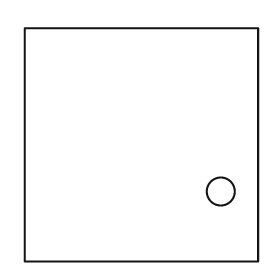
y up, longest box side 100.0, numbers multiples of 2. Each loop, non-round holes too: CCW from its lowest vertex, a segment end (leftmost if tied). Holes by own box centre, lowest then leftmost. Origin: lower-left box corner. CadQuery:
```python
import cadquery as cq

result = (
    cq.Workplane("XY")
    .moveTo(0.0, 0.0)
    .lineTo(100.0, 0.0)
    .lineTo(100.0, 100.0)
    .lineTo(0.0, 100.0)
    .close()
    .moveTo(84.0, 30.0)
    .circle(6.0)
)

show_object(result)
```